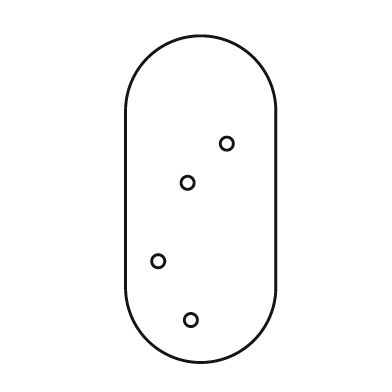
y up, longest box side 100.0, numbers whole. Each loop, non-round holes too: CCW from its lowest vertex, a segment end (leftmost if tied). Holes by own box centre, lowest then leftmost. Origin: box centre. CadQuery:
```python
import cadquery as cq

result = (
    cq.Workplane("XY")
    .moveTo(-23.0, -27.0)
    .threePointArc((0.0, -50.0), (23.0, -27.0))
    .lineTo(23.0, 27.0)
    .threePointArc((0.0, 50.0), (-23.0, 27.0))
    .close()
    .moveTo(-3.0, -37.0)
    .circle(2.0)
    .moveTo(-13.0, -19.0)
    .circle(2.0)
    .moveTo(-4.0, 5.0)
    .circle(2.0)
    .moveTo(8.0, 17.0)
    .circle(2.0)
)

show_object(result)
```